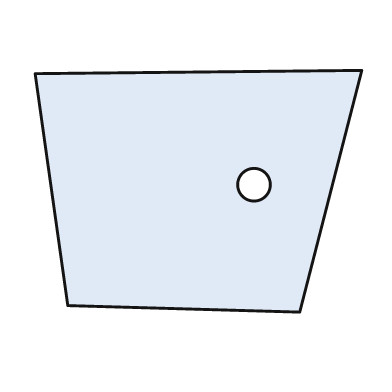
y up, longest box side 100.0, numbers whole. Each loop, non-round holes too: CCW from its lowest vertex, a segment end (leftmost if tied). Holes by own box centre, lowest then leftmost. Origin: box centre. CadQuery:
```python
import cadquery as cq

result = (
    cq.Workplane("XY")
    .moveTo(31.0, -37.0)
    .lineTo(50.0, 37.0)
    .lineTo(-50.0, 36.0)
    .lineTo(-40.0, -35.0)
    .close()
    .moveTo(17.0, 2.0)
    .circle(5.0)
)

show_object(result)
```